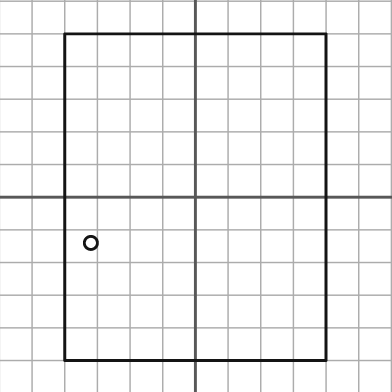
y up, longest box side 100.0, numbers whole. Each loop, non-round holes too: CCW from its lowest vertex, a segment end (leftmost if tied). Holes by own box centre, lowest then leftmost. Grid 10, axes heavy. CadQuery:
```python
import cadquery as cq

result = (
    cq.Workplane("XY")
    .moveTo(-40.0, -50.0)
    .lineTo(40.0, -50.0)
    .lineTo(40.0, 50.0)
    .lineTo(-40.0, 50.0)
    .close()
    .moveTo(-32.0, -14.0)
    .circle(2.0)
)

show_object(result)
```